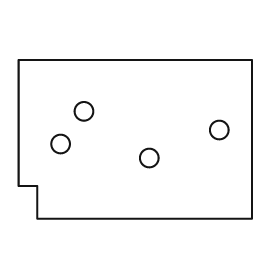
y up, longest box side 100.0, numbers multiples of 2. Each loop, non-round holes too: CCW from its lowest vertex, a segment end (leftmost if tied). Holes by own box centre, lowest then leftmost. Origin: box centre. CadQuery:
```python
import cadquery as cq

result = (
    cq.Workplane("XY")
    .moveTo(-42.0, -34.0)
    .lineTo(50.0, -34.0)
    .lineTo(50.0, 34.0)
    .lineTo(-50.0, 34.0)
    .lineTo(-50.0, -20.0)
    .lineTo(-42.0, -20.0)
    .close()
    .moveTo(6.0, -8.0)
    .circle(4.0)
    .moveTo(-32.0, -2.0)
    .circle(4.0)
    .moveTo(36.0, 4.0)
    .circle(4.0)
    .moveTo(-22.0, 12.0)
    .circle(4.0)
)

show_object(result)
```